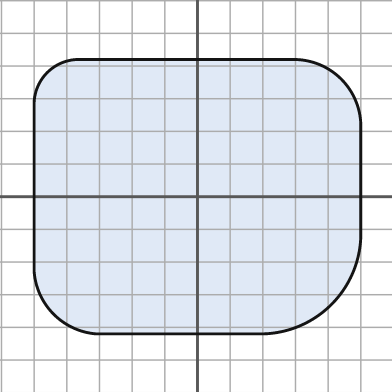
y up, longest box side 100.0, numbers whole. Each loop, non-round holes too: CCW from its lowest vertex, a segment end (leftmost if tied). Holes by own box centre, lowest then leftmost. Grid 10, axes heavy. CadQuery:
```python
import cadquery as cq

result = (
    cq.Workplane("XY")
    .moveTo(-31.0, -42.0)
    .lineTo(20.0, -42.0)
    .threePointArc((41.0, -33.0), (50.0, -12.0))
    .lineTo(50.0, 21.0)
    .threePointArc((44.0, 36.0), (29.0, 42.0))
    .lineTo(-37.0, 42.0)
    .threePointArc((-46.0, 38.0), (-50.0, 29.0))
    .lineTo(-50.0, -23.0)
    .threePointArc((-44.0, -36.0), (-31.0, -42.0))
    .close()
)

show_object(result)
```